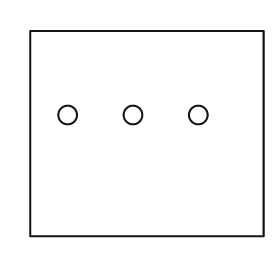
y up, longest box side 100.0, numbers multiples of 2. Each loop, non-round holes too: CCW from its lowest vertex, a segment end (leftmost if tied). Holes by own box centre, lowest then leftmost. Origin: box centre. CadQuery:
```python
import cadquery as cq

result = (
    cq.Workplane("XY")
    .moveTo(-50.0, -44.0)
    .lineTo(50.0, -44.0)
    .lineTo(50.0, 44.0)
    .lineTo(-50.0, 44.0)
    .close()
    .moveTo(-34.0, 8.0)
    .circle(4.0)
    .moveTo(-6.0, 8.0)
    .circle(4.0)
    .moveTo(22.0, 8.0)
    .circle(4.0)
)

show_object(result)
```